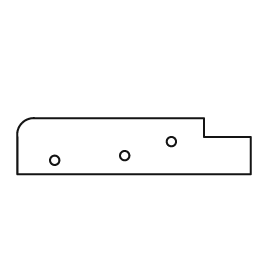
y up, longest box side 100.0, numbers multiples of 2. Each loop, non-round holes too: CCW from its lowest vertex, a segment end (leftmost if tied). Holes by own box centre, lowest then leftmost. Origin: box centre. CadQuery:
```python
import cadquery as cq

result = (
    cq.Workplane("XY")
    .moveTo(-50.0, -12.0)
    .lineTo(50.0, -12.0)
    .lineTo(50.0, 4.0)
    .lineTo(30.0, 4.0)
    .lineTo(30.0, 12.0)
    .lineTo(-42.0, 12.0)
    .threePointArc((-48.0, 10.0), (-50.0, 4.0))
    .close()
    .moveTo(-34.0, -6.0)
    .circle(2.0)
    .moveTo(-4.0, -4.0)
    .circle(2.0)
    .moveTo(16.0, 2.0)
    .circle(2.0)
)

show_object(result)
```